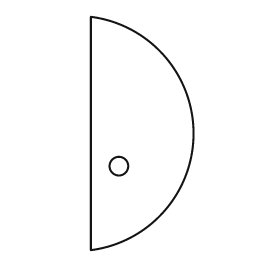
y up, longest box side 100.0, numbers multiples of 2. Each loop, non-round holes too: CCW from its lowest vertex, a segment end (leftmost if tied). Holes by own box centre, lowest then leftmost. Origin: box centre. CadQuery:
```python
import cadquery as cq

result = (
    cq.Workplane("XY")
    .moveTo(-22.0, -50.0)
    .threePointArc((22.0, 0.0), (-22.0, 50.0))
    .close()
    .moveTo(-10.0, -14.0)
    .circle(4.0)
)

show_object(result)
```